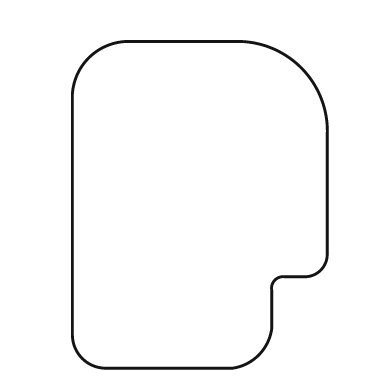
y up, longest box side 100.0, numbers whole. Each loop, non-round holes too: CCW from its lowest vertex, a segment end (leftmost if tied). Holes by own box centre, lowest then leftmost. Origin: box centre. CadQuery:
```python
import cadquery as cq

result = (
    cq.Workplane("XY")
    .moveTo(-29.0, -50.0)
    .lineTo(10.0, -50.0)
    .threePointArc((18.0, -46.0), (22.0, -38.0))
    .lineTo(22.0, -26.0)
    .threePointArc((23.0, -23.0), (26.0, -22.0))
    .lineTo(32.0, -22.0)
    .threePointArc((37.0, -20.0), (39.0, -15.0))
    .lineTo(39.0, 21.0)
    .threePointArc((31.0, 42.0), (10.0, 50.0))
    .lineTo(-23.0, 50.0)
    .threePointArc((-34.0, 45.0), (-39.0, 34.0))
    .lineTo(-39.0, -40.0)
    .threePointArc((-36.0, -47.0), (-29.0, -50.0))
    .close()
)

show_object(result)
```